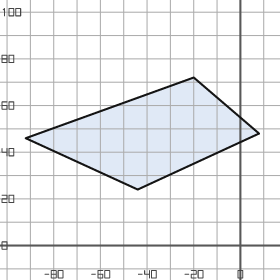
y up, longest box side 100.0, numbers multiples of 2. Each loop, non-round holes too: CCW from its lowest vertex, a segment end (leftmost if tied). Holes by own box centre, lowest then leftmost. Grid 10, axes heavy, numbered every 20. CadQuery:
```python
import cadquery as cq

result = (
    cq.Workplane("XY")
    .moveTo(-44.0, 24.0)
    .lineTo(8.0, 48.0)
    .lineTo(-20.0, 72.0)
    .lineTo(-92.0, 46.0)
    .close()
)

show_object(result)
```